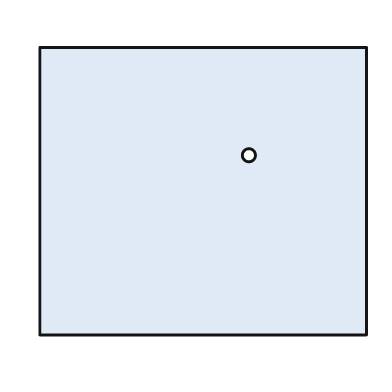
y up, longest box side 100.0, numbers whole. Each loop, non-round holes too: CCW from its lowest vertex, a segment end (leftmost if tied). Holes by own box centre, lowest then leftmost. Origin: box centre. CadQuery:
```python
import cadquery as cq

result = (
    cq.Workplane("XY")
    .moveTo(-50.0, -44.0)
    .lineTo(50.0, -44.0)
    .lineTo(50.0, 44.0)
    .lineTo(-50.0, 44.0)
    .close()
    .moveTo(14.0, 11.0)
    .circle(2.0)
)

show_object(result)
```